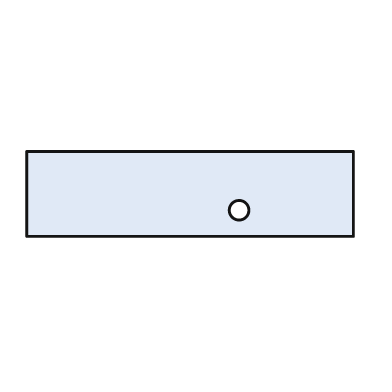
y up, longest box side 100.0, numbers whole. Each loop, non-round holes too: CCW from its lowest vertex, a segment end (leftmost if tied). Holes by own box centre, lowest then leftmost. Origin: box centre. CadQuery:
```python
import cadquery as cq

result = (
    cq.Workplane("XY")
    .moveTo(-50.0, -13.0)
    .lineTo(50.0, -13.0)
    .lineTo(50.0, 13.0)
    .lineTo(-50.0, 13.0)
    .close()
    .moveTo(15.0, -5.0)
    .circle(3.0)
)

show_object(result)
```